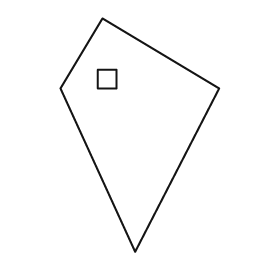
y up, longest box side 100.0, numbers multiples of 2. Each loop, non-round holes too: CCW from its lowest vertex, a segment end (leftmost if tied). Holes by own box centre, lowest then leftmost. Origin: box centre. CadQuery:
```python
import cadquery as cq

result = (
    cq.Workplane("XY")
    .moveTo(-2.0, -50.0)
    .lineTo(34.0, 20.0)
    .lineTo(-16.0, 50.0)
    .lineTo(-34.0, 20.0)
    .close()
    .moveTo(-18.0, 20.0)
    .lineTo(-10.0, 20.0)
    .lineTo(-10.0, 28.0)
    .lineTo(-18.0, 28.0)
    .close()
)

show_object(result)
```